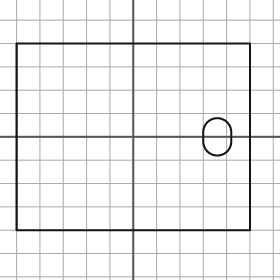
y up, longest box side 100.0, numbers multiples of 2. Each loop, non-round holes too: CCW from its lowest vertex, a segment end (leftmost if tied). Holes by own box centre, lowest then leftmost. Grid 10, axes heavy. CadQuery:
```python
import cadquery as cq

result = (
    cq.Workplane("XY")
    .moveTo(-50.0, -40.0)
    .lineTo(50.0, -40.0)
    .lineTo(50.0, 40.0)
    .lineTo(-50.0, 40.0)
    .close()
    .moveTo(30.0, -2.0)
    .threePointArc((36.0, -8.0), (42.0, -2.0))
    .lineTo(42.0, 2.0)
    .threePointArc((36.0, 8.0), (30.0, 2.0))
    .close()
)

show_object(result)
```